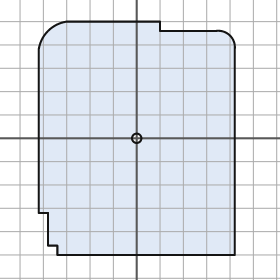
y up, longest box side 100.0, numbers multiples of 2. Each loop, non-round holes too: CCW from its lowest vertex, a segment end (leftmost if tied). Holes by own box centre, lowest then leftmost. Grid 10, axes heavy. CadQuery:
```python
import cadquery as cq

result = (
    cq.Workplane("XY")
    .moveTo(-34.0, -50.0)
    .lineTo(42.0, -50.0)
    .lineTo(42.0, 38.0)
    .threePointArc((40.0, 44.0), (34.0, 46.0))
    .lineTo(10.0, 46.0)
    .lineTo(10.0, 50.0)
    .lineTo(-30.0, 50.0)
    .threePointArc((-38.0, 46.0), (-42.0, 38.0))
    .lineTo(-42.0, -32.0)
    .lineTo(-38.0, -32.0)
    .lineTo(-38.0, -46.0)
    .lineTo(-34.0, -46.0)
    .close()
    .moveTo(0.0, 0.0)
    .circle(2.0)
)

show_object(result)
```